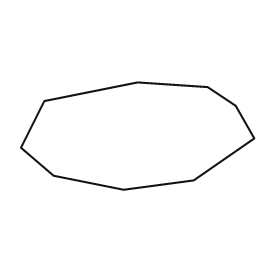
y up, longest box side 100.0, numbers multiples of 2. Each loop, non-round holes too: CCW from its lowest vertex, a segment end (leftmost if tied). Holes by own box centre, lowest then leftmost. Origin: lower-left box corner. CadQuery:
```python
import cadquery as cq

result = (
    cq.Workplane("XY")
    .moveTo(44.0, 0.0)
    .lineTo(74.0, 4.0)
    .lineTo(100.0, 22.0)
    .lineTo(92.0, 36.0)
    .lineTo(80.0, 44.0)
    .lineTo(50.0, 46.0)
    .lineTo(10.0, 38.0)
    .lineTo(0.0, 18.0)
    .lineTo(14.0, 6.0)
    .close()
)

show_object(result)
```